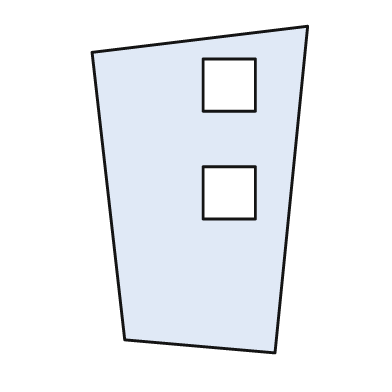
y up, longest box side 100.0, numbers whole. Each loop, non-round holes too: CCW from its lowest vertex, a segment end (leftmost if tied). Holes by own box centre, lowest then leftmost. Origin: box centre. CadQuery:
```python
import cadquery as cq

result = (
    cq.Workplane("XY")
    .moveTo(23.0, -50.0)
    .lineTo(33.0, 50.0)
    .lineTo(-33.0, 42.0)
    .lineTo(-23.0, -46.0)
    .close()
    .moveTo(1.0, -9.0)
    .lineTo(17.0, -9.0)
    .lineTo(17.0, 7.0)
    .lineTo(1.0, 7.0)
    .close()
    .moveTo(1.0, 24.0)
    .lineTo(17.0, 24.0)
    .lineTo(17.0, 40.0)
    .lineTo(1.0, 40.0)
    .close()
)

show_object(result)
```